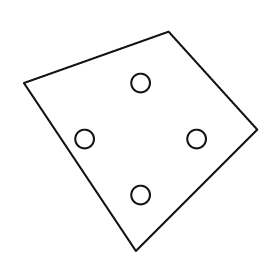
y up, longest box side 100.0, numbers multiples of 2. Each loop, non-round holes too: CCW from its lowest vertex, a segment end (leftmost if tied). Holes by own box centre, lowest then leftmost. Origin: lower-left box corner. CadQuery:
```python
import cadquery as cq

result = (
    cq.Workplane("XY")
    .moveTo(48.0, 0.0)
    .lineTo(100.0, 52.0)
    .lineTo(62.0, 94.0)
    .lineTo(0.0, 72.0)
    .close()
    .moveTo(50.0, 24.0)
    .circle(4.0)
    .moveTo(26.0, 48.0)
    .circle(4.0)
    .moveTo(74.0, 48.0)
    .circle(4.0)
    .moveTo(50.0, 72.0)
    .circle(4.0)
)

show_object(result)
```